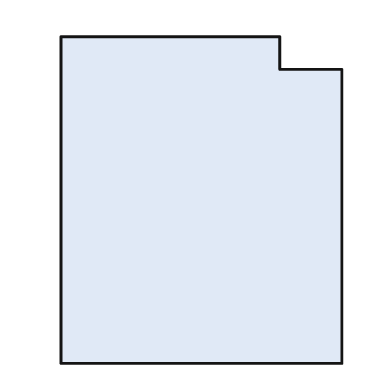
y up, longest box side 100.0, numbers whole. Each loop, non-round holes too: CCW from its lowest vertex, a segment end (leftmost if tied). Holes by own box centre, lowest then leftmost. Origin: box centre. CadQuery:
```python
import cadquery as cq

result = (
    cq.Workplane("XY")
    .moveTo(-43.0, -50.0)
    .lineTo(43.0, -50.0)
    .lineTo(43.0, 40.0)
    .lineTo(24.0, 40.0)
    .lineTo(24.0, 50.0)
    .lineTo(-43.0, 50.0)
    .close()
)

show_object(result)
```